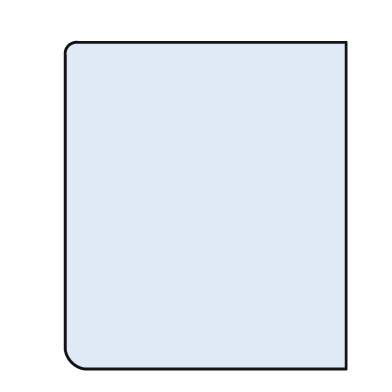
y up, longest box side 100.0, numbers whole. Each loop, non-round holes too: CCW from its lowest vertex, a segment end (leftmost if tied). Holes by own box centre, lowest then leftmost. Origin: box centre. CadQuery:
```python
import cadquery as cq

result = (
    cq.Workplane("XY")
    .moveTo(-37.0, -50.0)
    .lineTo(43.0, -50.0)
    .lineTo(43.0, 50.0)
    .lineTo(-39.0, 50.0)
    .threePointArc((-42.0, 49.0), (-43.0, 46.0))
    .lineTo(-43.0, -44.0)
    .threePointArc((-41.0, -48.0), (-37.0, -50.0))
    .close()
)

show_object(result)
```